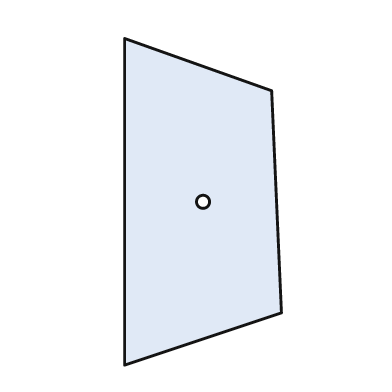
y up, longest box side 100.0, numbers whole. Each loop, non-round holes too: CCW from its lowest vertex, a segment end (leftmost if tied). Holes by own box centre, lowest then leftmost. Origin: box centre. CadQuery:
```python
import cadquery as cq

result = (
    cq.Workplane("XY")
    .moveTo(-24.0, -50.0)
    .lineTo(24.0, -34.0)
    .lineTo(21.0, 34.0)
    .lineTo(-24.0, 50.0)
    .close()
    .moveTo(0.0, 0.0)
    .circle(2.0)
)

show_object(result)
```